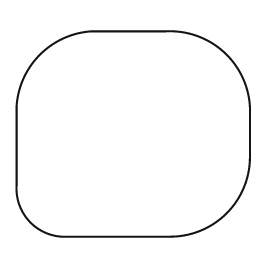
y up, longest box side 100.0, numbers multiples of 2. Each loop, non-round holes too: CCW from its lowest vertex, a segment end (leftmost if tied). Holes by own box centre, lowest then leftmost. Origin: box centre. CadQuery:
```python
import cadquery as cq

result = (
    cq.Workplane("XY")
    .moveTo(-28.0, -44.0)
    .lineTo(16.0, -44.0)
    .threePointArc((40.0, -34.0), (50.0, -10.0))
    .lineTo(50.0, 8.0)
    .threePointArc((40.0, 34.0), (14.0, 44.0))
    .lineTo(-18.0, 44.0)
    .threePointArc((-40.0, 34.0), (-50.0, 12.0))
    .lineTo(-50.0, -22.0)
    .threePointArc((-44.0, -38.0), (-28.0, -44.0))
    .close()
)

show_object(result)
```